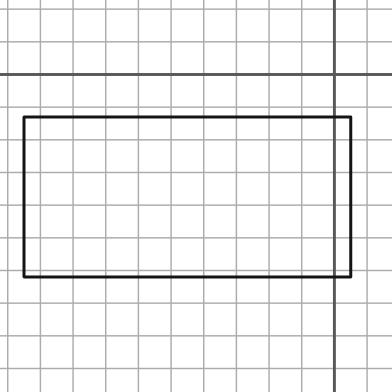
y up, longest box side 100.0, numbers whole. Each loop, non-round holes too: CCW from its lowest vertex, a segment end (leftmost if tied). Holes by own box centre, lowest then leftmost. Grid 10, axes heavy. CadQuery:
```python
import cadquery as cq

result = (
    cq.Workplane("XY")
    .moveTo(-95.0, -62.0)
    .lineTo(5.0, -62.0)
    .lineTo(5.0, -13.0)
    .lineTo(-95.0, -13.0)
    .close()
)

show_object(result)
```